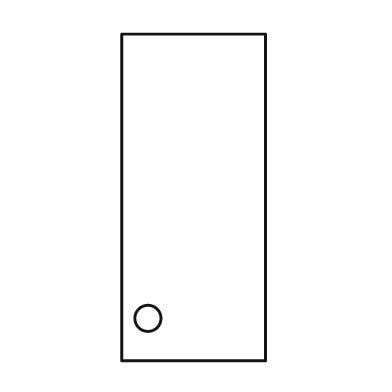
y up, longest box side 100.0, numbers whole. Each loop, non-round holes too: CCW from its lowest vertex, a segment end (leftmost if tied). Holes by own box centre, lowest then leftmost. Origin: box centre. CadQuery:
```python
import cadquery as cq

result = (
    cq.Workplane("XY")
    .moveTo(-22.0, -50.0)
    .lineTo(22.0, -50.0)
    .lineTo(22.0, 50.0)
    .lineTo(-22.0, 50.0)
    .close()
    .moveTo(-14.0, -37.0)
    .circle(4.0)
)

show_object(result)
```